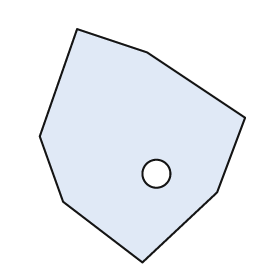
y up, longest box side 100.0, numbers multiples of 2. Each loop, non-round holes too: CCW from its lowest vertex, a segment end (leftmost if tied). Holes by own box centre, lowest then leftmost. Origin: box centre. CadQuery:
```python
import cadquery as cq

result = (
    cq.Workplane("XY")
    .moveTo(0.0, -50.0)
    .lineTo(32.0, -20.0)
    .lineTo(44.0, 12.0)
    .lineTo(2.0, 40.0)
    .lineTo(-28.0, 50.0)
    .lineTo(-44.0, 4.0)
    .lineTo(-34.0, -24.0)
    .close()
    .moveTo(6.0, -12.0)
    .circle(6.0)
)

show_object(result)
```